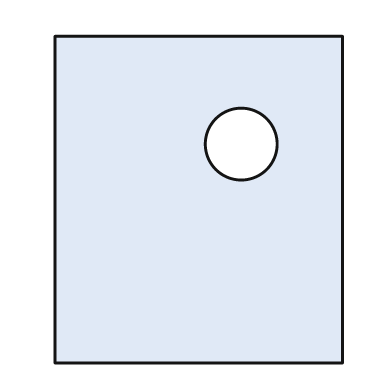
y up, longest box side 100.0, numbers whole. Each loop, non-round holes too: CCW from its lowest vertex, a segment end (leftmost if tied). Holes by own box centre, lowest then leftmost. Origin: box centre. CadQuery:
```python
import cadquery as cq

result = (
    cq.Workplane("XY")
    .moveTo(-44.0, -50.0)
    .lineTo(44.0, -50.0)
    .lineTo(44.0, 50.0)
    .lineTo(-44.0, 50.0)
    .close()
    .moveTo(13.0, 17.0)
    .circle(11.0)
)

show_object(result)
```